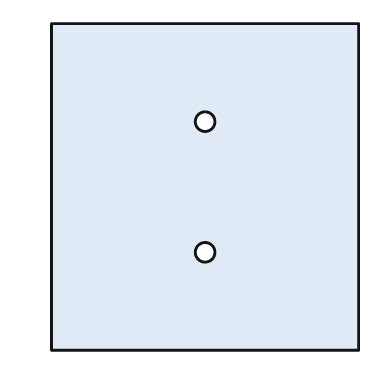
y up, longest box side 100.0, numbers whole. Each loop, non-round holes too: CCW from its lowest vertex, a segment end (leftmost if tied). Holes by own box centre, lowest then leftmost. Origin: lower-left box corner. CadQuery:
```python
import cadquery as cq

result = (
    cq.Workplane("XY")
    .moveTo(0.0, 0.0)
    .lineTo(94.0, 0.0)
    .lineTo(94.0, 100.0)
    .lineTo(0.0, 100.0)
    .close()
    .moveTo(47.0, 30.0)
    .circle(3.0)
    .moveTo(47.0, 70.0)
    .circle(3.0)
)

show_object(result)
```